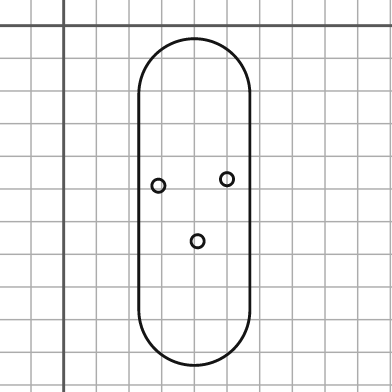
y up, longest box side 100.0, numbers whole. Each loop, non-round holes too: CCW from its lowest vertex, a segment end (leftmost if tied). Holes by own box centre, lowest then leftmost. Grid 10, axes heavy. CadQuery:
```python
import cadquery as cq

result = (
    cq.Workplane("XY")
    .moveTo(23.0, -87.0)
    .threePointArc((40.0, -104.0), (57.0, -87.0))
    .lineTo(57.0, -21.0)
    .threePointArc((40.0, -4.0), (23.0, -21.0))
    .close()
    .moveTo(41.0, -66.0)
    .circle(2.0)
    .moveTo(29.0, -49.0)
    .circle(2.0)
    .moveTo(50.0, -47.0)
    .circle(2.0)
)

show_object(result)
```